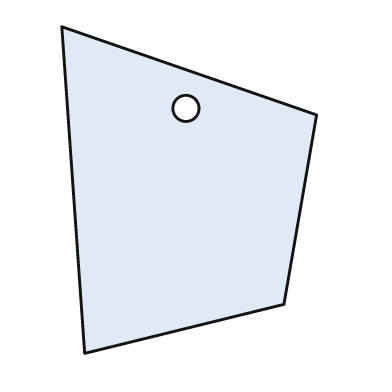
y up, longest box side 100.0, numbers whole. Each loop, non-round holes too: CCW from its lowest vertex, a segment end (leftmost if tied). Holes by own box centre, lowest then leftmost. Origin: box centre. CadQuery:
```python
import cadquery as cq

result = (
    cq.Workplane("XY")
    .moveTo(-32.0, -50.0)
    .lineTo(29.0, -35.0)
    .lineTo(39.0, 23.0)
    .lineTo(-39.0, 50.0)
    .close()
    .moveTo(-1.0, 25.0)
    .circle(4.0)
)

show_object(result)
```